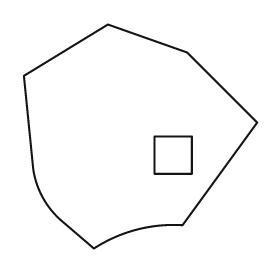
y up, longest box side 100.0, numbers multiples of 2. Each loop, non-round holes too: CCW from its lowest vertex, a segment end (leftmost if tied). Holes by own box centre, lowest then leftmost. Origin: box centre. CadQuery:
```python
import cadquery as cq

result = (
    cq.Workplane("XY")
    .moveTo(-20.0, -48.0)
    .threePointArc((-2.0, -40.0), (18.0, -38.0))
    .lineTo(50.0, 6.0)
    .lineTo(20.0, 36.0)
    .lineTo(-14.0, 48.0)
    .lineTo(-50.0, 26.0)
    .lineTo(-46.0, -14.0)
    .threePointArc((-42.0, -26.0), (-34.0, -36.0))
    .close()
    .moveTo(6.0, -16.0)
    .lineTo(22.0, -16.0)
    .lineTo(22.0, 0.0)
    .lineTo(6.0, 0.0)
    .close()
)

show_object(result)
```